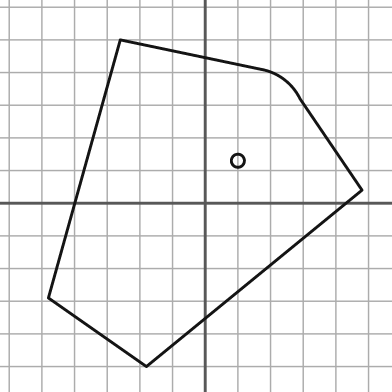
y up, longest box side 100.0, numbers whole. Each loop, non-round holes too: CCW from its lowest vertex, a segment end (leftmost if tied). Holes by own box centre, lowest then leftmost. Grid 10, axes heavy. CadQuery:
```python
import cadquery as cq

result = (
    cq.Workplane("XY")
    .moveTo(-18.0, -50.0)
    .lineTo(48.0, 4.0)
    .lineTo(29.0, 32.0)
    .threePointArc((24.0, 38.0), (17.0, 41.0))
    .lineTo(-26.0, 50.0)
    .lineTo(-48.0, -29.0)
    .close()
    .moveTo(10.0, 13.0)
    .circle(2.0)
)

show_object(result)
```